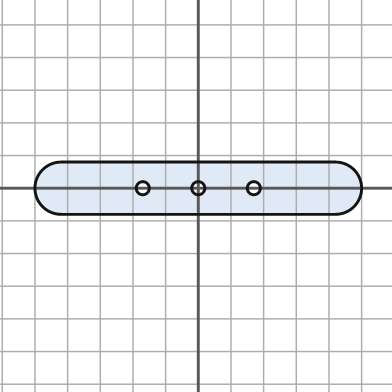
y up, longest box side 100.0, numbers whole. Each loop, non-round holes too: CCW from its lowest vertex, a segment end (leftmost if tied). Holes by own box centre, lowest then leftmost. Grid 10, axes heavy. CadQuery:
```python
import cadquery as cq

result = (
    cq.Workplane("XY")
    .moveTo(-42.0, -8.0)
    .lineTo(42.0, -8.0)
    .threePointArc((50.0, 0.0), (42.0, 8.0))
    .lineTo(-42.0, 8.0)
    .threePointArc((-50.0, 0.0), (-42.0, -8.0))
    .close()
    .moveTo(-17.0, 0.0)
    .circle(2.0)
    .moveTo(0.0, 0.0)
    .circle(2.0)
    .moveTo(17.0, 0.0)
    .circle(2.0)
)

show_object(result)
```